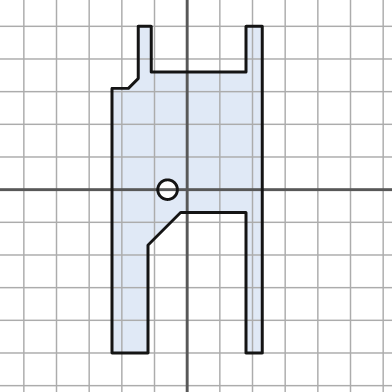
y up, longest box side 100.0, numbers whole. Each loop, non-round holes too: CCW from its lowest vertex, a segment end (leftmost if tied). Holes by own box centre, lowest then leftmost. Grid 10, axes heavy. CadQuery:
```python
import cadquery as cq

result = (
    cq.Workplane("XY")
    .moveTo(-23.0, -50.0)
    .lineTo(-12.0, -50.0)
    .lineTo(-12.0, -17.0)
    .lineTo(-2.0, -7.0)
    .lineTo(18.0, -7.0)
    .lineTo(18.0, -50.0)
    .lineTo(23.0, -50.0)
    .lineTo(23.0, 50.0)
    .lineTo(18.0, 50.0)
    .lineTo(18.0, 36.0)
    .lineTo(-11.0, 36.0)
    .lineTo(-11.0, 50.0)
    .lineTo(-15.0, 50.0)
    .lineTo(-15.0, 34.0)
    .lineTo(-18.0, 31.0)
    .lineTo(-23.0, 31.0)
    .close()
    .moveTo(-6.0, 0.0)
    .circle(3.0)
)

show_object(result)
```